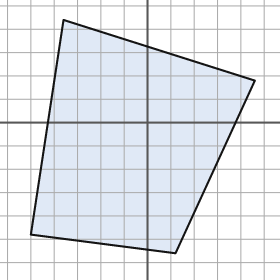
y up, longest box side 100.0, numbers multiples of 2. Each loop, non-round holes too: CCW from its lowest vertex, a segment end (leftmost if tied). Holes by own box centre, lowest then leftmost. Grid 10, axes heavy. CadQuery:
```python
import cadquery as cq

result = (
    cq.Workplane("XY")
    .moveTo(12.0, -56.0)
    .lineTo(46.0, 18.0)
    .lineTo(-36.0, 44.0)
    .lineTo(-50.0, -48.0)
    .close()
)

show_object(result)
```